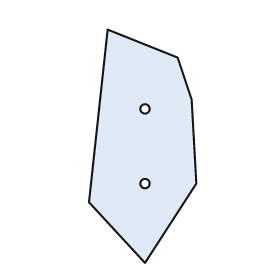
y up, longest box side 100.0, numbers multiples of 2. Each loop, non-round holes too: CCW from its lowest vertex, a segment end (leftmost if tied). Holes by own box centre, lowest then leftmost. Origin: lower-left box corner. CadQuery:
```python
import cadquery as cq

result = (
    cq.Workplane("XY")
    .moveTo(24.0, 0.0)
    .lineTo(46.0, 34.0)
    .lineTo(44.0, 70.0)
    .lineTo(38.0, 88.0)
    .lineTo(8.0, 100.0)
    .lineTo(0.0, 26.0)
    .close()
    .moveTo(24.0, 34.0)
    .circle(2.0)
    .moveTo(24.0, 66.0)
    .circle(2.0)
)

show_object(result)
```